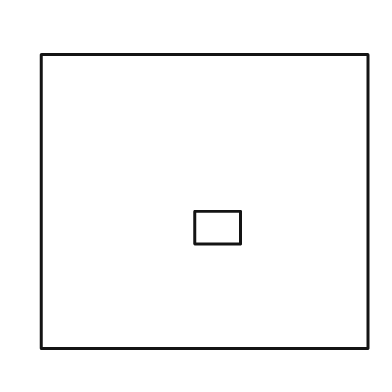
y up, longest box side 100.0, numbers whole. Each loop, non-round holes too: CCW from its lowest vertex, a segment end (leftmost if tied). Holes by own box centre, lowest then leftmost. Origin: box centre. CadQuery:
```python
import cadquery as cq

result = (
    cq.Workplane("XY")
    .moveTo(-50.0, -45.0)
    .lineTo(50.0, -45.0)
    .lineTo(50.0, 45.0)
    .lineTo(-50.0, 45.0)
    .close()
    .moveTo(-3.0, -13.0)
    .lineTo(11.0, -13.0)
    .lineTo(11.0, -3.0)
    .lineTo(-3.0, -3.0)
    .close()
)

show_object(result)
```